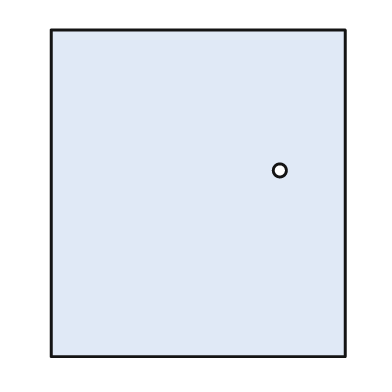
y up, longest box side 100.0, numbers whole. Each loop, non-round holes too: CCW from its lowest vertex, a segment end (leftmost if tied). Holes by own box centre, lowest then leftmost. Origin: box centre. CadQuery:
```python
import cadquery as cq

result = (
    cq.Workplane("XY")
    .moveTo(-45.0, -50.0)
    .lineTo(45.0, -50.0)
    .lineTo(45.0, 50.0)
    .lineTo(-45.0, 50.0)
    .close()
    .moveTo(25.0, 7.0)
    .circle(2.0)
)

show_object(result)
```